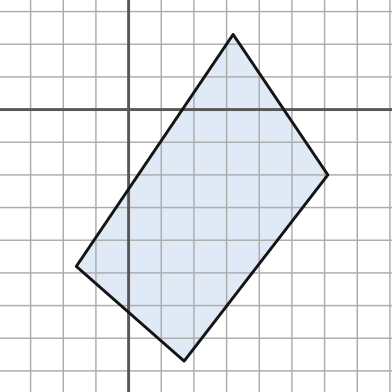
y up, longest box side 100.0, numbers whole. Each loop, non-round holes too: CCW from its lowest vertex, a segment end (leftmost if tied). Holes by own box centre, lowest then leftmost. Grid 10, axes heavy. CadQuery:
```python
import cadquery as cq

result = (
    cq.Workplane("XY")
    .moveTo(17.0, -77.0)
    .lineTo(61.0, -20.0)
    .lineTo(32.0, 23.0)
    .lineTo(-16.0, -48.0)
    .close()
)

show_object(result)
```